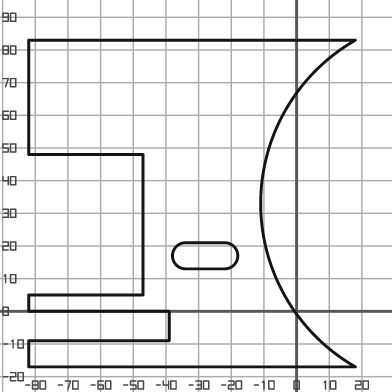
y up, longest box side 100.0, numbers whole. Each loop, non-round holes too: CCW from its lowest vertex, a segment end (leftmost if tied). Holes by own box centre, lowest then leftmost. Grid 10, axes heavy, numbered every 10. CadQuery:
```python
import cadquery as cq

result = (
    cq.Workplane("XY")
    .moveTo(-82.0, -17.0)
    .lineTo(18.0, -17.0)
    .threePointArc((-11.0, 33.0), (18.0, 83.0))
    .lineTo(-82.0, 83.0)
    .lineTo(-82.0, 48.0)
    .lineTo(-47.0, 48.0)
    .lineTo(-47.0, 5.0)
    .lineTo(-82.0, 5.0)
    .lineTo(-82.0, 0.0)
    .lineTo(-39.0, 0.0)
    .lineTo(-39.0, -9.0)
    .lineTo(-82.0, -9.0)
    .close()
    .moveTo(-34.0, 13.0)
    .lineTo(-22.0, 13.0)
    .threePointArc((-18.0, 17.0), (-22.0, 21.0))
    .lineTo(-34.0, 21.0)
    .threePointArc((-38.0, 17.0), (-34.0, 13.0))
    .close()
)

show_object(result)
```